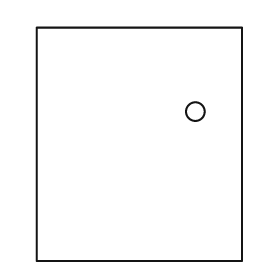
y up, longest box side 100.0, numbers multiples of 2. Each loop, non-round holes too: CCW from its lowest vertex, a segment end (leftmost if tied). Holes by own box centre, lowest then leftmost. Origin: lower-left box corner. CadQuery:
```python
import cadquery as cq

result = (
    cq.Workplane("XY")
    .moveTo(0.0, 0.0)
    .lineTo(88.0, 0.0)
    .lineTo(88.0, 100.0)
    .lineTo(0.0, 100.0)
    .close()
    .moveTo(68.0, 64.0)
    .circle(4.0)
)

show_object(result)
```